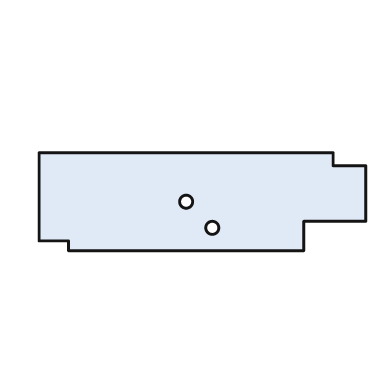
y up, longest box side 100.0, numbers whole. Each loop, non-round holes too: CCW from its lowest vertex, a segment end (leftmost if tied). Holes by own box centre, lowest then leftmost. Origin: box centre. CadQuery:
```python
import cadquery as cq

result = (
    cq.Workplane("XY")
    .moveTo(-41.0, -15.0)
    .lineTo(31.0, -15.0)
    .lineTo(31.0, -6.0)
    .lineTo(50.0, -6.0)
    .lineTo(50.0, 11.0)
    .lineTo(40.0, 11.0)
    .lineTo(40.0, 15.0)
    .lineTo(-50.0, 15.0)
    .lineTo(-50.0, -12.0)
    .lineTo(-41.0, -12.0)
    .close()
    .moveTo(3.0, -8.0)
    .circle(2.0)
    .moveTo(-5.0, 0.0)
    .circle(2.0)
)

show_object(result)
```